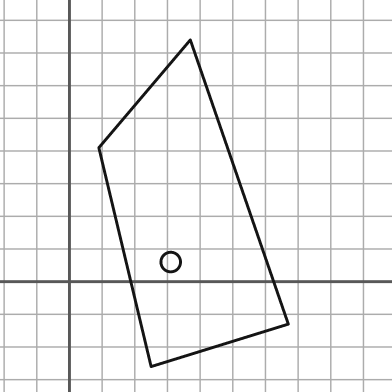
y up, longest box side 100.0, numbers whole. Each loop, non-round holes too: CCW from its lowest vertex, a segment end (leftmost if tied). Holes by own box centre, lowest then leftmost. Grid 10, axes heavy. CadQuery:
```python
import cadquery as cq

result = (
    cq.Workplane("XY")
    .moveTo(25.0, -26.0)
    .lineTo(67.0, -13.0)
    .lineTo(37.0, 74.0)
    .lineTo(9.0, 41.0)
    .close()
    .moveTo(31.0, 6.0)
    .circle(3.0)
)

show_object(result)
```